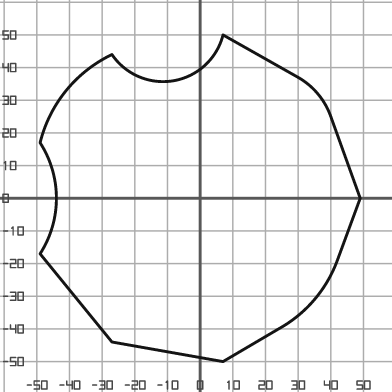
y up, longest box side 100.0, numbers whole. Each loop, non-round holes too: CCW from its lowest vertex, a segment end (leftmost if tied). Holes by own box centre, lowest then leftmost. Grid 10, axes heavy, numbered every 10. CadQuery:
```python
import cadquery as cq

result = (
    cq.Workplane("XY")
    .moveTo(7.0, -50.0)
    .lineTo(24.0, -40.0)
    .threePointArc((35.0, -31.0), (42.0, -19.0))
    .lineTo(49.0, 0.0)
    .lineTo(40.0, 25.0)
    .threePointArc((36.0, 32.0), (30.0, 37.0))
    .lineTo(7.0, 50.0)
    .threePointArc((-8.0, 36.0), (-27.0, 44.0))
    .threePointArc((-41.0, 33.0), (-49.0, 17.0))
    .threePointArc((-44.0, 0.0), (-49.0, -17.0))
    .lineTo(-27.0, -44.0)
    .close()
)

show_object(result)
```